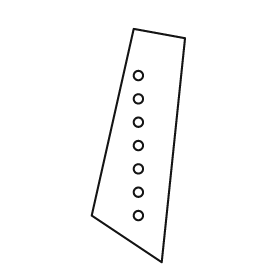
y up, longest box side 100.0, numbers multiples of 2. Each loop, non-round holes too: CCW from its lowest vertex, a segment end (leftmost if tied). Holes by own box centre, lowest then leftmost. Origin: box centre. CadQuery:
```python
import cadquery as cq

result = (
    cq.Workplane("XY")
    .moveTo(10.0, -50.0)
    .lineTo(20.0, 46.0)
    .lineTo(-2.0, 50.0)
    .lineTo(-20.0, -30.0)
    .close()
    .moveTo(0.0, -30.0)
    .circle(2.0)
    .moveTo(0.0, -20.0)
    .circle(2.0)
    .moveTo(0.0, -10.0)
    .circle(2.0)
    .moveTo(0.0, 0.0)
    .circle(2.0)
    .moveTo(0.0, 10.0)
    .circle(2.0)
    .moveTo(0.0, 20.0)
    .circle(2.0)
    .moveTo(0.0, 30.0)
    .circle(2.0)
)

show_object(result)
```